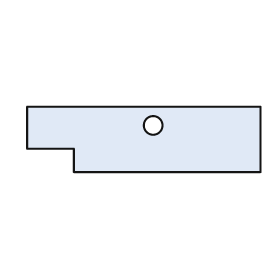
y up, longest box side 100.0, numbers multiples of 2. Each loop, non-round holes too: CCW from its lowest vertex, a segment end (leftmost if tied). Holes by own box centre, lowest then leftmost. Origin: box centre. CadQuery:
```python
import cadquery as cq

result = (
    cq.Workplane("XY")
    .moveTo(-30.0, -14.0)
    .lineTo(50.0, -14.0)
    .lineTo(50.0, 14.0)
    .lineTo(-50.0, 14.0)
    .lineTo(-50.0, -4.0)
    .lineTo(-30.0, -4.0)
    .close()
    .moveTo(4.0, 6.0)
    .circle(4.0)
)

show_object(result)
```